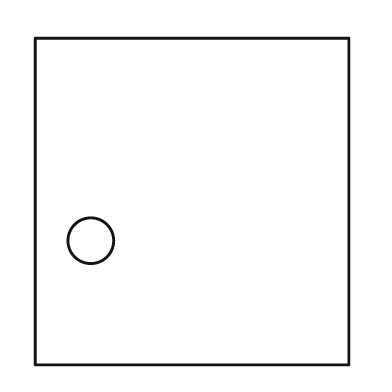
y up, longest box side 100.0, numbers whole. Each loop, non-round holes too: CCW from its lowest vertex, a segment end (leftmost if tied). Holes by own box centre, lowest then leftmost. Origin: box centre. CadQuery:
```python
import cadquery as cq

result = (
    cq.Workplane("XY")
    .moveTo(-48.0, -50.0)
    .lineTo(48.0, -50.0)
    .lineTo(48.0, 50.0)
    .lineTo(-48.0, 50.0)
    .close()
    .moveTo(-31.0, -12.0)
    .circle(7.0)
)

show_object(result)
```